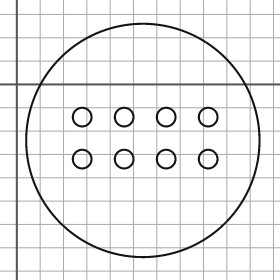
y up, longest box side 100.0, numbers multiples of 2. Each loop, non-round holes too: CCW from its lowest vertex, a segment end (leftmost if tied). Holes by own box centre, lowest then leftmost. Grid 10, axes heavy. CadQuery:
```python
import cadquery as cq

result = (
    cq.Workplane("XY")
    .moveTo(54.0, -24.0)
    .circle(50.0)
    .moveTo(28.0, -32.0)
    .circle(4.0)
    .moveTo(46.0, -32.0)
    .circle(4.0)
    .moveTo(64.0, -32.0)
    .circle(4.0)
    .moveTo(82.0, -32.0)
    .circle(4.0)
    .moveTo(28.0, -14.0)
    .circle(4.0)
    .moveTo(46.0, -14.0)
    .circle(4.0)
    .moveTo(64.0, -14.0)
    .circle(4.0)
    .moveTo(82.0, -14.0)
    .circle(4.0)
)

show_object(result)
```